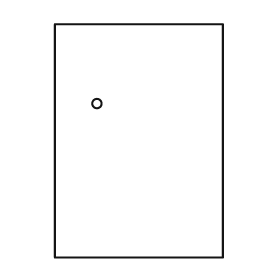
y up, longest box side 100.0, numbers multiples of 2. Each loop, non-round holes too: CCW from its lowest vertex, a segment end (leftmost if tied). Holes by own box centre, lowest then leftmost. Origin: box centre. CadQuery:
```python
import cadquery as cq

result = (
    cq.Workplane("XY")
    .moveTo(-36.0, -50.0)
    .lineTo(36.0, -50.0)
    .lineTo(36.0, 50.0)
    .lineTo(-36.0, 50.0)
    .close()
    .moveTo(-18.0, 16.0)
    .circle(2.0)
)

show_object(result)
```